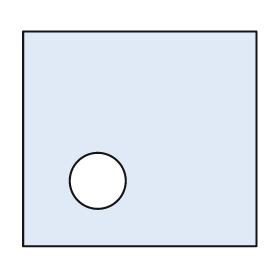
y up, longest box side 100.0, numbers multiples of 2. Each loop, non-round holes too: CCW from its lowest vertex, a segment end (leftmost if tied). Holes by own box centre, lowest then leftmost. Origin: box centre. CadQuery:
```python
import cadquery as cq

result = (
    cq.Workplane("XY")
    .moveTo(-50.0, -46.0)
    .lineTo(50.0, -46.0)
    .lineTo(50.0, 46.0)
    .lineTo(-50.0, 46.0)
    .close()
    .moveTo(-18.0, -18.0)
    .circle(12.0)
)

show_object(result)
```